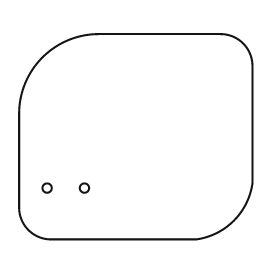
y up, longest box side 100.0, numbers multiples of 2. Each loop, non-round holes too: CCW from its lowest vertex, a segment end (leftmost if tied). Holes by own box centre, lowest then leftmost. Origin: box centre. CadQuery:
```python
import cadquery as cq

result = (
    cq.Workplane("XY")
    .moveTo(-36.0, -44.0)
    .lineTo(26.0, -44.0)
    .threePointArc((42.0, -36.0), (50.0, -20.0))
    .lineTo(50.0, 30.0)
    .threePointArc((46.0, 40.0), (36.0, 44.0))
    .lineTo(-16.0, 44.0)
    .threePointArc((-40.0, 34.0), (-50.0, 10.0))
    .lineTo(-50.0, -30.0)
    .threePointArc((-46.0, -40.0), (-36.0, -44.0))
    .close()
    .moveTo(-38.0, -22.0)
    .circle(2.0)
    .moveTo(-22.0, -22.0)
    .circle(2.0)
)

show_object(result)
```